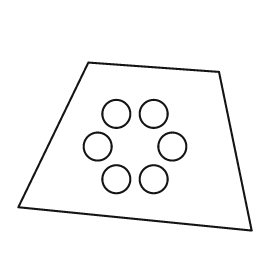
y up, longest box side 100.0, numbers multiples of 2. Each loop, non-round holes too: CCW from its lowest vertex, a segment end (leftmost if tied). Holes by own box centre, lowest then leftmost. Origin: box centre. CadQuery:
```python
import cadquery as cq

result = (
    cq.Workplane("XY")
    .moveTo(50.0, -36.0)
    .lineTo(36.0, 32.0)
    .lineTo(-20.0, 36.0)
    .lineTo(-50.0, -26.0)
    .close()
    .moveTo(-8.0, -14.0)
    .circle(6.0)
    .moveTo(8.0, -14.0)
    .circle(6.0)
    .moveTo(-16.0, 0.0)
    .circle(6.0)
    .moveTo(16.0, 0.0)
    .circle(6.0)
    .moveTo(-8.0, 14.0)
    .circle(6.0)
    .moveTo(8.0, 14.0)
    .circle(6.0)
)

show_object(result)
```